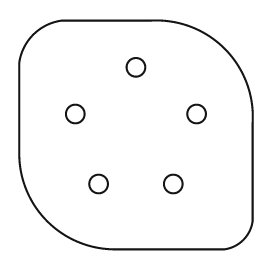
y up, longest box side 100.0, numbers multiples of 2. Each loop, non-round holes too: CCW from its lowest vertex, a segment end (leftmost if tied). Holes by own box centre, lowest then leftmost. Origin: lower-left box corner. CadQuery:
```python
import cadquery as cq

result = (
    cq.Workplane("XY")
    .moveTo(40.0, 0.0)
    .lineTo(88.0, 0.0)
    .threePointArc((96.0, 4.0), (100.0, 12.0))
    .lineTo(100.0, 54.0)
    .threePointArc((88.0, 86.0), (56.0, 98.0))
    .lineTo(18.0, 98.0)
    .threePointArc((6.0, 92.0), (0.0, 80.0))
    .lineTo(0.0, 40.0)
    .threePointArc((12.0, 12.0), (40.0, 0.0))
    .close()
    .moveTo(34.0, 28.0)
    .circle(4.0)
    .moveTo(66.0, 28.0)
    .circle(4.0)
    .moveTo(24.0, 58.0)
    .circle(4.0)
    .moveTo(76.0, 58.0)
    .circle(4.0)
    .moveTo(50.0, 78.0)
    .circle(4.0)
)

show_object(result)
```